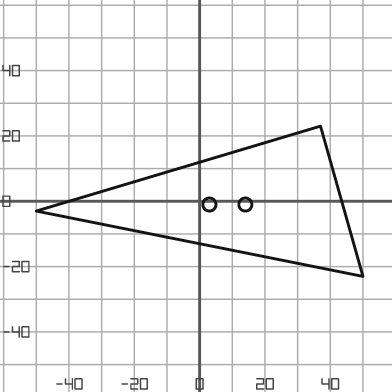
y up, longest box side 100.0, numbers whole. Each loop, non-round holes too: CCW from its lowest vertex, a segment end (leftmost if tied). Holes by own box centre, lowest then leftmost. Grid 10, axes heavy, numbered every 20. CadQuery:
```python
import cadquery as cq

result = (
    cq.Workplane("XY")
    .moveTo(50.0, -23.0)
    .lineTo(37.0, 23.0)
    .lineTo(-50.0, -3.0)
    .close()
    .moveTo(3.0, -1.0)
    .circle(2.0)
    .moveTo(14.0, -1.0)
    .circle(2.0)
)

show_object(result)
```